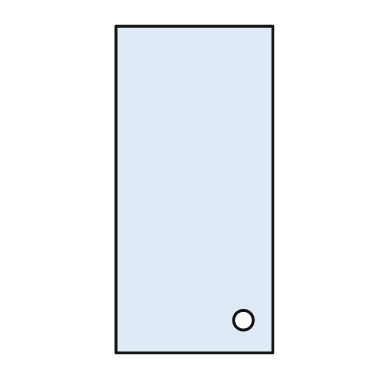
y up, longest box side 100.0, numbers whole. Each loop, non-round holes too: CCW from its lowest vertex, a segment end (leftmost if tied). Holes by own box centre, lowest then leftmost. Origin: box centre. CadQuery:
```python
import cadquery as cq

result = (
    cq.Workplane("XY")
    .moveTo(-24.0, -50.0)
    .lineTo(24.0, -50.0)
    .lineTo(24.0, 50.0)
    .lineTo(-24.0, 50.0)
    .close()
    .moveTo(15.0, -40.0)
    .circle(3.0)
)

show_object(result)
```